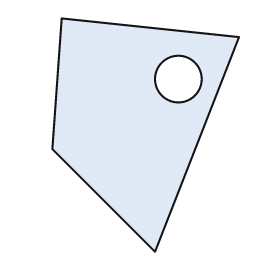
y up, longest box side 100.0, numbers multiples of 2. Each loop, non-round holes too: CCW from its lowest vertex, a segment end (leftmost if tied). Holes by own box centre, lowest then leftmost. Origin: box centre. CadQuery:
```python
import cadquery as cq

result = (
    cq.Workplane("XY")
    .moveTo(4.0, -50.0)
    .lineTo(40.0, 42.0)
    .lineTo(-36.0, 50.0)
    .lineTo(-40.0, -6.0)
    .close()
    .moveTo(14.0, 24.0)
    .circle(10.0)
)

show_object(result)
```